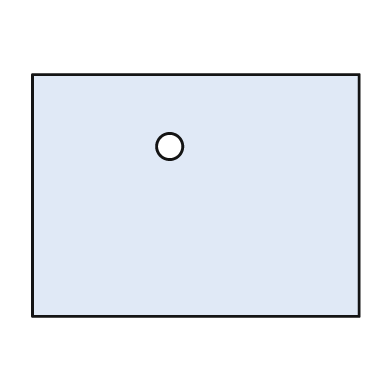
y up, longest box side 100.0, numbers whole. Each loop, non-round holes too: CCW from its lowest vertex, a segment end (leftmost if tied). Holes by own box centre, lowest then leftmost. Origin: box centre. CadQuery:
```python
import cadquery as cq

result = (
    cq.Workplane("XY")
    .moveTo(-50.0, -37.0)
    .lineTo(50.0, -37.0)
    .lineTo(50.0, 37.0)
    .lineTo(-50.0, 37.0)
    .close()
    .moveTo(-8.0, 15.0)
    .circle(4.0)
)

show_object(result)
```